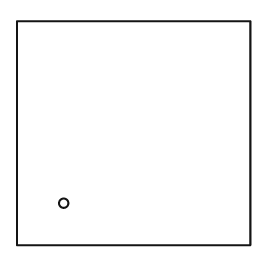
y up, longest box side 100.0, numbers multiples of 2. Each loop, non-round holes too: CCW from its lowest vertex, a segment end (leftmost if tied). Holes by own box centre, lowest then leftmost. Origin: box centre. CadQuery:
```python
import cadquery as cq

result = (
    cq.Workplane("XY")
    .moveTo(-50.0, -48.0)
    .lineTo(50.0, -48.0)
    .lineTo(50.0, 48.0)
    .lineTo(-50.0, 48.0)
    .close()
    .moveTo(-30.0, -30.0)
    .circle(2.0)
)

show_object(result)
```